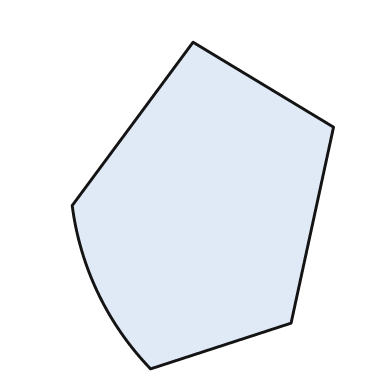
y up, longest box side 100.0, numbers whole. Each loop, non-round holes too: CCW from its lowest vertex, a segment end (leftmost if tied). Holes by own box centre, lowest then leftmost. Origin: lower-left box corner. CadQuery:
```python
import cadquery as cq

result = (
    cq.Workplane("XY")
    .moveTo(24.0, 0.0)
    .lineTo(67.0, 14.0)
    .lineTo(80.0, 74.0)
    .lineTo(37.0, 100.0)
    .lineTo(0.0, 50.0)
    .threePointArc((8.0, 23.0), (24.0, 0.0))
    .close()
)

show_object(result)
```